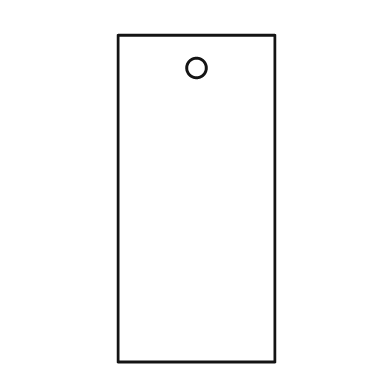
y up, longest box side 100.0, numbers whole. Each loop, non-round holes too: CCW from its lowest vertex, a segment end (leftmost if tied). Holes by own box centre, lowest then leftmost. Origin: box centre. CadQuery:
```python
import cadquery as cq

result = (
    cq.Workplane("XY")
    .moveTo(-24.0, -50.0)
    .lineTo(24.0, -50.0)
    .lineTo(24.0, 50.0)
    .lineTo(-24.0, 50.0)
    .close()
    .moveTo(0.0, 40.0)
    .circle(3.0)
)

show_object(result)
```